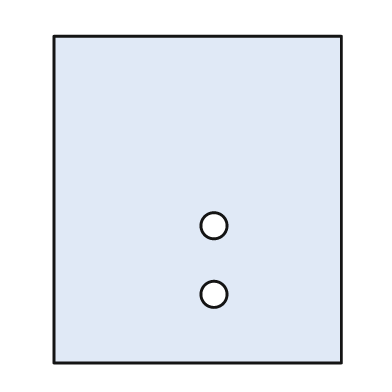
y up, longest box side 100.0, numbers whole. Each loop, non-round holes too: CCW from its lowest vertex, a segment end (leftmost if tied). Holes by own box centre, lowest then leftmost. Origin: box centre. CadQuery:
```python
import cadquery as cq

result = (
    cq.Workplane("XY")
    .moveTo(-44.0, -50.0)
    .lineTo(44.0, -50.0)
    .lineTo(44.0, 50.0)
    .lineTo(-44.0, 50.0)
    .close()
    .moveTo(5.0, -29.0)
    .circle(4.0)
    .moveTo(5.0, -8.0)
    .circle(4.0)
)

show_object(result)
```